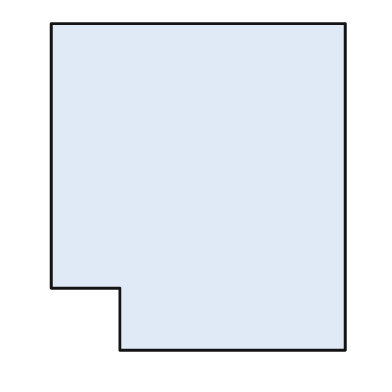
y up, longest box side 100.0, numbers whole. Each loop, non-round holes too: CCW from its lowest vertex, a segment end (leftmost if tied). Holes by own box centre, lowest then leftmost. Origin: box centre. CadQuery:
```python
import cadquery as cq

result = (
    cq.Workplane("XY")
    .moveTo(-24.0, -50.0)
    .lineTo(45.0, -50.0)
    .lineTo(45.0, 50.0)
    .lineTo(-45.0, 50.0)
    .lineTo(-45.0, -31.0)
    .lineTo(-24.0, -31.0)
    .close()
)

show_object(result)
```